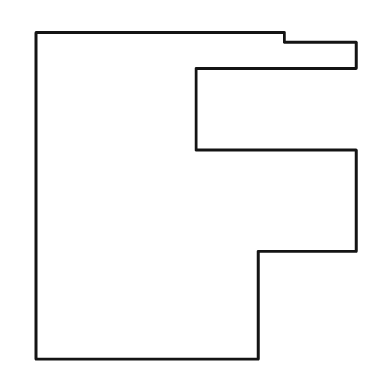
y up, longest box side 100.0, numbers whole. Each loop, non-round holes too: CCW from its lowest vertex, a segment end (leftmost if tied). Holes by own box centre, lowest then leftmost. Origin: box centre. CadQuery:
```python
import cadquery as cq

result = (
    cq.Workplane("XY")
    .moveTo(-49.0, -50.0)
    .lineTo(19.0, -50.0)
    .lineTo(19.0, -17.0)
    .lineTo(49.0, -17.0)
    .lineTo(49.0, 14.0)
    .lineTo(0.0, 14.0)
    .lineTo(0.0, 39.0)
    .lineTo(49.0, 39.0)
    .lineTo(49.0, 47.0)
    .lineTo(27.0, 47.0)
    .lineTo(27.0, 50.0)
    .lineTo(-49.0, 50.0)
    .close()
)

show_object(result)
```